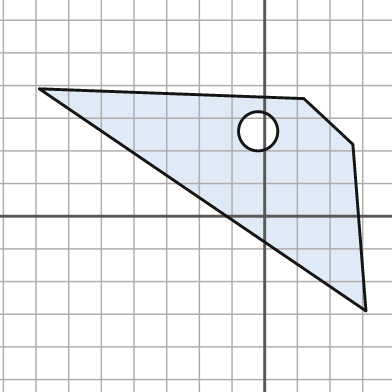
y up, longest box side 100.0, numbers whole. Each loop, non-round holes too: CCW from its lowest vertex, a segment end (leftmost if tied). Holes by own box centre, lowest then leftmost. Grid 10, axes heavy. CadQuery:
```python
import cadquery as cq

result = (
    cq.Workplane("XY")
    .moveTo(31.0, -29.0)
    .lineTo(27.0, 22.0)
    .lineTo(12.0, 36.0)
    .lineTo(-69.0, 39.0)
    .close()
    .moveTo(-2.0, 26.0)
    .circle(6.0)
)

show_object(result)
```